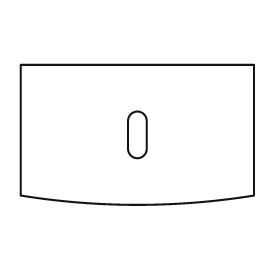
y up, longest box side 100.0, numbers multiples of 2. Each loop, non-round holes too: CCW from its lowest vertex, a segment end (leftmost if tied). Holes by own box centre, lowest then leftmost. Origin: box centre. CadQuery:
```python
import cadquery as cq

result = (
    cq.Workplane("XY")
    .moveTo(-50.0, -26.0)
    .threePointArc((0.0, -30.0), (50.0, -26.0))
    .lineTo(50.0, 30.0)
    .lineTo(-50.0, 30.0)
    .close()
    .moveTo(-4.0, -6.0)
    .threePointArc((0.0, -10.0), (4.0, -6.0))
    .lineTo(4.0, 6.0)
    .threePointArc((0.0, 10.0), (-4.0, 6.0))
    .close()
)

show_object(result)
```